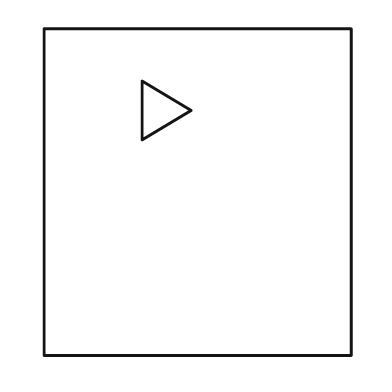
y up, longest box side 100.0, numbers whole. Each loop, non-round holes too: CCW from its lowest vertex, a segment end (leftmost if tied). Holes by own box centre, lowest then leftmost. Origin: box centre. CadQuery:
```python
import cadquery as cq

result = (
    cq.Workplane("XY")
    .moveTo(-47.0, -50.0)
    .lineTo(47.0, -50.0)
    .lineTo(47.0, 50.0)
    .lineTo(-47.0, 50.0)
    .close()
    .moveTo(-17.0, 16.0)
    .lineTo(-2.0, 25.0)
    .lineTo(-17.0, 34.0)
    .close()
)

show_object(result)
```